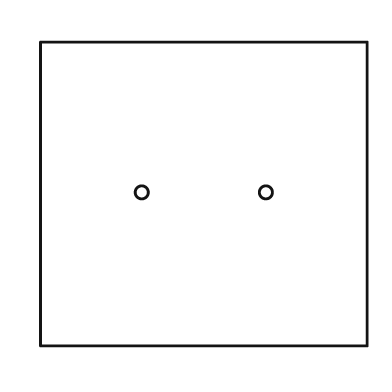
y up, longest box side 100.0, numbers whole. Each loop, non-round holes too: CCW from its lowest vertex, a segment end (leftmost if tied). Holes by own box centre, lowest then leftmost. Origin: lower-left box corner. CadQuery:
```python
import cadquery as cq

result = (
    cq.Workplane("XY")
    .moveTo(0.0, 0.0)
    .lineTo(100.0, 0.0)
    .lineTo(100.0, 93.0)
    .lineTo(0.0, 93.0)
    .close()
    .moveTo(31.0, 47.0)
    .circle(2.0)
    .moveTo(69.0, 47.0)
    .circle(2.0)
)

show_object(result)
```